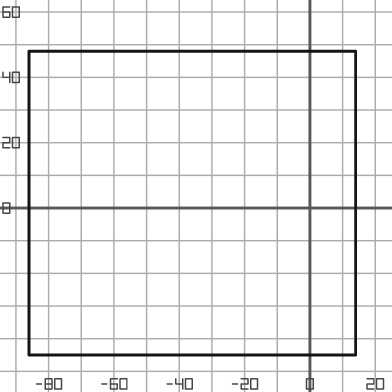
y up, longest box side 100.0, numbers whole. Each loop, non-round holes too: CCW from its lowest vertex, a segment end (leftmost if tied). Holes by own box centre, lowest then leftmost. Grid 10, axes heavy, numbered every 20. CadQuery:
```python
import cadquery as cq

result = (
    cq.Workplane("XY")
    .moveTo(-86.0, -45.0)
    .lineTo(14.0, -45.0)
    .lineTo(14.0, 48.0)
    .lineTo(-86.0, 48.0)
    .close()
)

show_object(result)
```